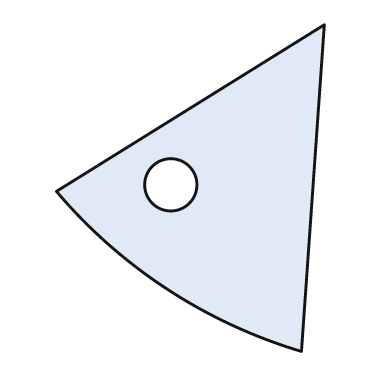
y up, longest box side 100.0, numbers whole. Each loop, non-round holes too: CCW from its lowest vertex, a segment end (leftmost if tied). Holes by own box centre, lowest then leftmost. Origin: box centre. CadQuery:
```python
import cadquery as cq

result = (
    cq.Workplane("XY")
    .moveTo(34.0, -50.0)
    .lineTo(41.0, 50.0)
    .lineTo(-41.0, -1.0)
    .threePointArc((-7.0, -31.0), (34.0, -50.0))
    .close()
    .moveTo(-6.0, 1.0)
    .circle(8.0)
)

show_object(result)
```